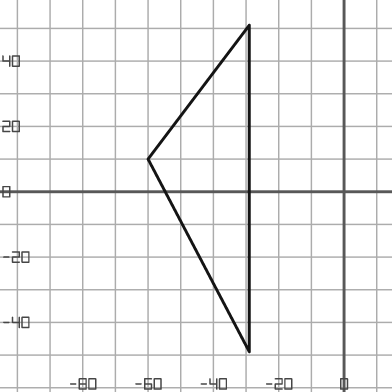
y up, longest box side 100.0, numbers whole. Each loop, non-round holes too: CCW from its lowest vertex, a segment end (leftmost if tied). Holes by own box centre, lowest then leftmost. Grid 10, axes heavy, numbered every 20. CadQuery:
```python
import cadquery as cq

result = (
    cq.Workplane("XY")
    .moveTo(-29.0, -49.0)
    .lineTo(-29.0, 51.0)
    .lineTo(-60.0, 10.0)
    .close()
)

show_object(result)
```